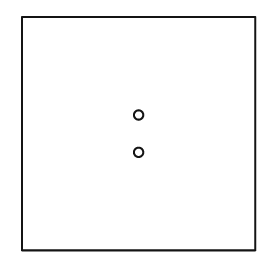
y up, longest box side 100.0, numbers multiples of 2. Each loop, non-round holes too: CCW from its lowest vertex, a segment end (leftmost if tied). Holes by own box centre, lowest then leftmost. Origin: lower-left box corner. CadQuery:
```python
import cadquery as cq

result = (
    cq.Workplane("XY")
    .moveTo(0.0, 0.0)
    .lineTo(100.0, 0.0)
    .lineTo(100.0, 100.0)
    .lineTo(0.0, 100.0)
    .close()
    .moveTo(50.0, 42.0)
    .circle(2.0)
    .moveTo(50.0, 58.0)
    .circle(2.0)
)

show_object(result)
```